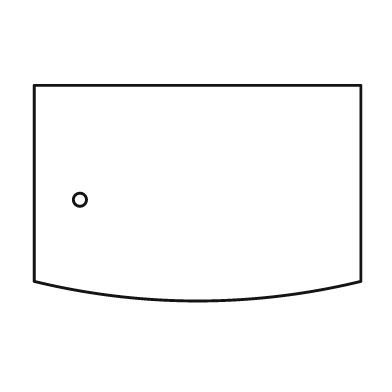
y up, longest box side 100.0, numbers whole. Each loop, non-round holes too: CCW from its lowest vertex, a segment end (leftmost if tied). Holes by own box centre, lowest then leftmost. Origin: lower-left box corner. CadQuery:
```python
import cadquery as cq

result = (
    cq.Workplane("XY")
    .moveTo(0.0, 6.0)
    .threePointArc((50.0, 0.0), (100.0, 6.0))
    .lineTo(100.0, 66.0)
    .lineTo(0.0, 66.0)
    .close()
    .moveTo(14.0, 31.0)
    .circle(2.0)
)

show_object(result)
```